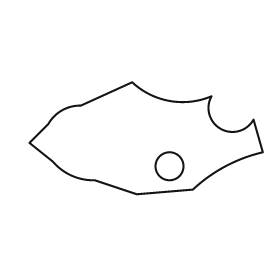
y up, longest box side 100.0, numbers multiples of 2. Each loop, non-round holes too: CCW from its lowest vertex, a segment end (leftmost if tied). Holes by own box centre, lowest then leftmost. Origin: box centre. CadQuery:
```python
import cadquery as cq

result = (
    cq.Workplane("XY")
    .moveTo(-4.0, -24.0)
    .lineTo(20.0, -22.0)
    .threePointArc((34.0, -12.0), (50.0, -6.0))
    .lineTo(46.0, 8.0)
    .threePointArc((32.0, 4.0), (28.0, 18.0))
    .threePointArc((10.0, 16.0), (-6.0, 24.0))
    .lineTo(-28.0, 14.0)
    .threePointArc((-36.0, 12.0), (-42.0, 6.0))
    .lineTo(-50.0, -2.0)
    .lineTo(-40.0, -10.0)
    .threePointArc((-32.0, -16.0), (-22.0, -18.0))
    .close()
    .moveTo(10.0, -12.0)
    .circle(6.0)
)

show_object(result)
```